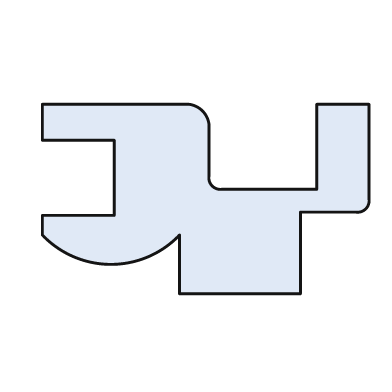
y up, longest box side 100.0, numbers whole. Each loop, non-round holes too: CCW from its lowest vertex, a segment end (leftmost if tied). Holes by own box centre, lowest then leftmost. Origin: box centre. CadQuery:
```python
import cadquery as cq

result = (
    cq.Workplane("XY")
    .moveTo(-8.0, -29.0)
    .lineTo(29.0, -29.0)
    .lineTo(29.0, -4.0)
    .lineTo(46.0, -4.0)
    .threePointArc((49.0, -3.0), (50.0, 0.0))
    .lineTo(50.0, 29.0)
    .lineTo(34.0, 29.0)
    .lineTo(34.0, 3.0)
    .lineTo(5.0, 3.0)
    .threePointArc((2.0, 4.0), (1.0, 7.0))
    .lineTo(1.0, 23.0)
    .threePointArc((-1.0, 27.0), (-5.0, 29.0))
    .lineTo(-50.0, 29.0)
    .lineTo(-50.0, 18.0)
    .lineTo(-28.0, 18.0)
    .lineTo(-28.0, -5.0)
    .lineTo(-50.0, -5.0)
    .lineTo(-50.0, -11.0)
    .threePointArc((-29.0, -20.0), (-8.0, -11.0))
    .close()
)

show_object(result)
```